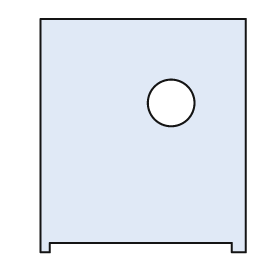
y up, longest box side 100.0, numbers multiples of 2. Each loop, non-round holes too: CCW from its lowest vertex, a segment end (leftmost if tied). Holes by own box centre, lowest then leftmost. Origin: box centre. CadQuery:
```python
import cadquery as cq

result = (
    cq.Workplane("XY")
    .moveTo(-44.0, -50.0)
    .lineTo(-40.0, -50.0)
    .lineTo(-40.0, -46.0)
    .lineTo(38.0, -46.0)
    .lineTo(38.0, -50.0)
    .lineTo(44.0, -50.0)
    .lineTo(44.0, 50.0)
    .lineTo(-44.0, 50.0)
    .close()
    .moveTo(12.0, 14.0)
    .circle(10.0)
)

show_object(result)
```